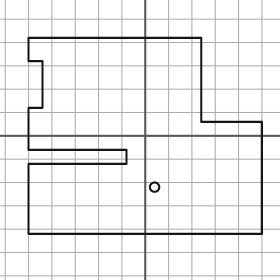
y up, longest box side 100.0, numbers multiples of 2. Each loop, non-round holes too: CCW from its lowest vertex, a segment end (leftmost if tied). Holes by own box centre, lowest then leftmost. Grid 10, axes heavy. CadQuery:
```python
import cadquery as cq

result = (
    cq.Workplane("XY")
    .moveTo(-50.0, -42.0)
    .lineTo(50.0, -42.0)
    .lineTo(50.0, 6.0)
    .lineTo(24.0, 6.0)
    .lineTo(24.0, 42.0)
    .lineTo(-50.0, 42.0)
    .lineTo(-50.0, 32.0)
    .lineTo(-44.0, 32.0)
    .lineTo(-44.0, 12.0)
    .lineTo(-50.0, 12.0)
    .lineTo(-50.0, -6.0)
    .lineTo(-8.0, -6.0)
    .lineTo(-8.0, -12.0)
    .lineTo(-50.0, -12.0)
    .close()
    .moveTo(4.0, -22.0)
    .circle(2.0)
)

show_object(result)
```